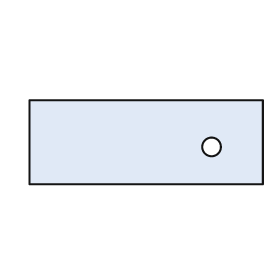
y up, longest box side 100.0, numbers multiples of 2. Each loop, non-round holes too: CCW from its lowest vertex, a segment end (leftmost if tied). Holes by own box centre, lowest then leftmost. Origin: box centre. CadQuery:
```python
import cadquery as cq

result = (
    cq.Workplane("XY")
    .moveTo(-50.0, -18.0)
    .lineTo(50.0, -18.0)
    .lineTo(50.0, 18.0)
    .lineTo(-50.0, 18.0)
    .close()
    .moveTo(28.0, -2.0)
    .circle(4.0)
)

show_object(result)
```